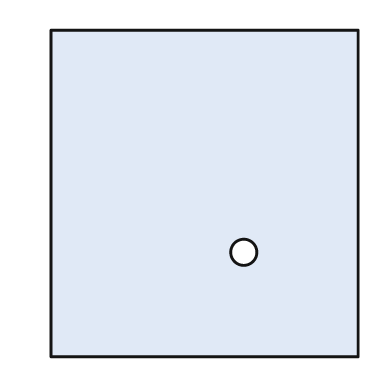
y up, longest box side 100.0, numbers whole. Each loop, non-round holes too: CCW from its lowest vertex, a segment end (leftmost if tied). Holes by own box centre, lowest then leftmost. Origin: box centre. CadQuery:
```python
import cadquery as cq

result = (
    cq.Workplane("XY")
    .moveTo(-47.0, -50.0)
    .lineTo(47.0, -50.0)
    .lineTo(47.0, 50.0)
    .lineTo(-47.0, 50.0)
    .close()
    .moveTo(12.0, -18.0)
    .circle(4.0)
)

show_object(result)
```